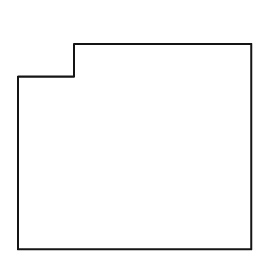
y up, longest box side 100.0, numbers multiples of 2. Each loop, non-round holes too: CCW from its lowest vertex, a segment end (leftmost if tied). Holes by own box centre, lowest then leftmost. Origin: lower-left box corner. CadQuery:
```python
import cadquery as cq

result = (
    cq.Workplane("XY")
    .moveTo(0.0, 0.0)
    .lineTo(100.0, 0.0)
    .lineTo(100.0, 88.0)
    .lineTo(24.0, 88.0)
    .lineTo(24.0, 74.0)
    .lineTo(0.0, 74.0)
    .close()
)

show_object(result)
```